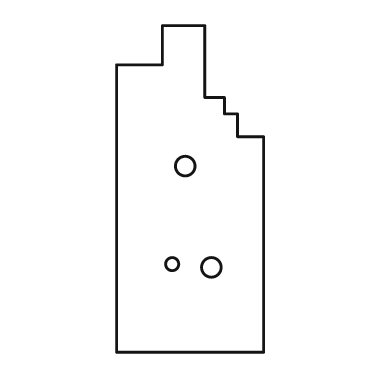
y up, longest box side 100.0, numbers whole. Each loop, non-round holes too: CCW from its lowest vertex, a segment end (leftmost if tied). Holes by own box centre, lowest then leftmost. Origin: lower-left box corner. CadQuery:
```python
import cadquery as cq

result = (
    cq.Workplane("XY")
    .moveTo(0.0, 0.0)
    .lineTo(45.0, 0.0)
    .lineTo(45.0, 66.0)
    .lineTo(37.0, 66.0)
    .lineTo(37.0, 73.0)
    .lineTo(33.0, 73.0)
    .lineTo(33.0, 78.0)
    .lineTo(27.0, 78.0)
    .lineTo(27.0, 100.0)
    .lineTo(14.0, 100.0)
    .lineTo(14.0, 88.0)
    .lineTo(0.0, 88.0)
    .close()
    .moveTo(29.0, 26.0)
    .circle(3.0)
    .moveTo(17.0, 27.0)
    .circle(2.0)
    .moveTo(21.0, 57.0)
    .circle(3.0)
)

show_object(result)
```